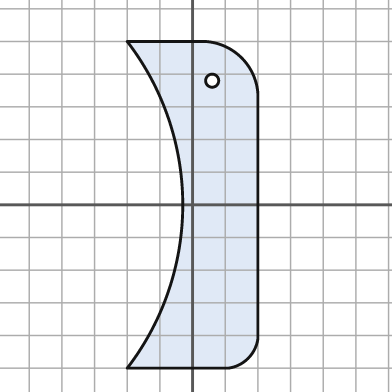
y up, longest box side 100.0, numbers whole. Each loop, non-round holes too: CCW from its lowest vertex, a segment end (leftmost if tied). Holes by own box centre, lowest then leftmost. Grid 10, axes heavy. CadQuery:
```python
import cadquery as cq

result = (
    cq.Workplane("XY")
    .moveTo(-20.0, -50.0)
    .lineTo(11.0, -50.0)
    .threePointArc((17.0, -47.0), (20.0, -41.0))
    .lineTo(20.0, 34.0)
    .threePointArc((15.0, 45.0), (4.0, 50.0))
    .lineTo(-20.0, 50.0)
    .threePointArc((-3.0, 0.0), (-20.0, -50.0))
    .close()
    .moveTo(6.0, 38.0)
    .circle(2.0)
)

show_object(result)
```